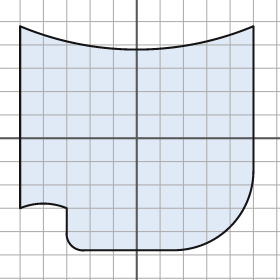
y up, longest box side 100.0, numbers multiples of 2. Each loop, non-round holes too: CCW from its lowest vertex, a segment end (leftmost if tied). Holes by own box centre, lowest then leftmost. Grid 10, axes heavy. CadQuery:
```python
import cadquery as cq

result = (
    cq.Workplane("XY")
    .moveTo(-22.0, -48.0)
    .lineTo(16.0, -48.0)
    .threePointArc((40.0, -38.0), (50.0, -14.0))
    .lineTo(50.0, 48.0)
    .threePointArc((0.0, 38.0), (-50.0, 48.0))
    .lineTo(-50.0, -30.0)
    .threePointArc((-40.0, -28.0), (-30.0, -30.0))
    .lineTo(-30.0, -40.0)
    .threePointArc((-28.0, -46.0), (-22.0, -48.0))
    .close()
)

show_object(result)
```